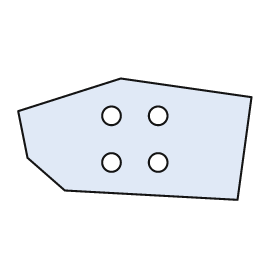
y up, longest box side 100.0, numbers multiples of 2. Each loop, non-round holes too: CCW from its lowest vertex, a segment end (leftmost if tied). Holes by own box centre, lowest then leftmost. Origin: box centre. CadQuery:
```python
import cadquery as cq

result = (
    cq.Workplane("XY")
    .moveTo(44.0, -26.0)
    .lineTo(50.0, 18.0)
    .lineTo(-6.0, 26.0)
    .lineTo(-50.0, 12.0)
    .lineTo(-46.0, -8.0)
    .lineTo(-30.0, -22.0)
    .close()
    .moveTo(-10.0, -10.0)
    .circle(4.0)
    .moveTo(10.0, -10.0)
    .circle(4.0)
    .moveTo(-10.0, 10.0)
    .circle(4.0)
    .moveTo(10.0, 10.0)
    .circle(4.0)
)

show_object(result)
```